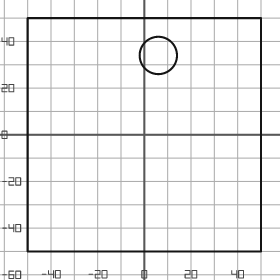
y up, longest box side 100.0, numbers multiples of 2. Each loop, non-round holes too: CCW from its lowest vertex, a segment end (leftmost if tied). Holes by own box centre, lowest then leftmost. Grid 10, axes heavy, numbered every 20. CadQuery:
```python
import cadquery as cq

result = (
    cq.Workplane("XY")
    .moveTo(-50.0, -50.0)
    .lineTo(50.0, -50.0)
    .lineTo(50.0, 50.0)
    .lineTo(-50.0, 50.0)
    .close()
    .moveTo(6.0, 34.0)
    .circle(8.0)
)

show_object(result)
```